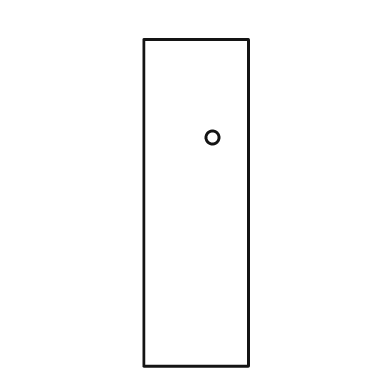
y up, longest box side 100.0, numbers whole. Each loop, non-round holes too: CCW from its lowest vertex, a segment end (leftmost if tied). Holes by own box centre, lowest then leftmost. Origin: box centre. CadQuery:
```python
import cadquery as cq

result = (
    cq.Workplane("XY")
    .moveTo(-16.0, -50.0)
    .lineTo(16.0, -50.0)
    .lineTo(16.0, 50.0)
    .lineTo(-16.0, 50.0)
    .close()
    .moveTo(5.0, 20.0)
    .circle(2.0)
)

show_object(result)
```